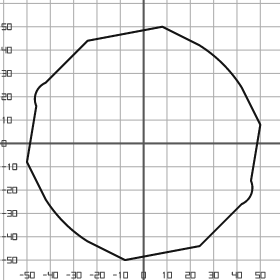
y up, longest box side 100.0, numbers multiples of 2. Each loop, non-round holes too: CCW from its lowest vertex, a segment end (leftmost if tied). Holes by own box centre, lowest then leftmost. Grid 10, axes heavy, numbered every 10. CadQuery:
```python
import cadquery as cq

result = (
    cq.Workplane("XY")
    .moveTo(-8.0, -50.0)
    .lineTo(24.0, -44.0)
    .lineTo(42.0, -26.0)
    .threePointArc((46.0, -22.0), (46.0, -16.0))
    .lineTo(50.0, 8.0)
    .lineTo(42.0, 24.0)
    .threePointArc((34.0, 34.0), (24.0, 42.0))
    .lineTo(8.0, 50.0)
    .lineTo(-24.0, 44.0)
    .lineTo(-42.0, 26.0)
    .threePointArc((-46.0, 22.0), (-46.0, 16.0))
    .lineTo(-50.0, -8.0)
    .lineTo(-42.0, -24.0)
    .threePointArc((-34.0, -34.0), (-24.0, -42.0))
    .close()
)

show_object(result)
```